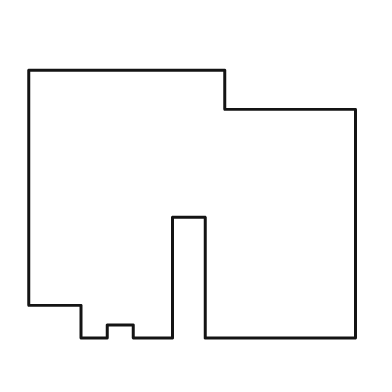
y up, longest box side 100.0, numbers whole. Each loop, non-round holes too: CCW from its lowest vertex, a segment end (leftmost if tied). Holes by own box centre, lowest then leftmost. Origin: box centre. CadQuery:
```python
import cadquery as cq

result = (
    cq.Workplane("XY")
    .moveTo(-34.0, -41.0)
    .lineTo(-26.0, -41.0)
    .lineTo(-26.0, -37.0)
    .lineTo(-18.0, -37.0)
    .lineTo(-18.0, -41.0)
    .lineTo(-6.0, -41.0)
    .lineTo(-6.0, -4.0)
    .lineTo(4.0, -4.0)
    .lineTo(4.0, -41.0)
    .lineTo(50.0, -41.0)
    .lineTo(50.0, 29.0)
    .lineTo(10.0, 29.0)
    .lineTo(10.0, 41.0)
    .lineTo(-50.0, 41.0)
    .lineTo(-50.0, -31.0)
    .lineTo(-34.0, -31.0)
    .close()
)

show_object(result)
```